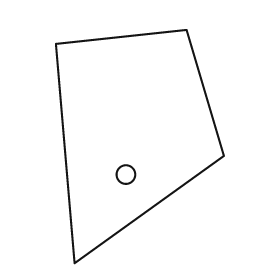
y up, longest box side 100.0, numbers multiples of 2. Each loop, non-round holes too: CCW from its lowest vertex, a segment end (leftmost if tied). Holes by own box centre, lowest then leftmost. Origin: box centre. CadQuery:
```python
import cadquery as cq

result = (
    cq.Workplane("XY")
    .moveTo(-28.0, -50.0)
    .lineTo(36.0, -4.0)
    .lineTo(20.0, 50.0)
    .lineTo(-36.0, 44.0)
    .close()
    .moveTo(-6.0, -12.0)
    .circle(4.0)
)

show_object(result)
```